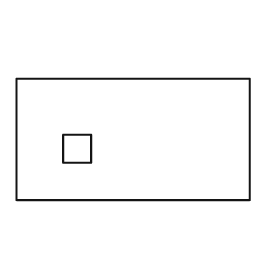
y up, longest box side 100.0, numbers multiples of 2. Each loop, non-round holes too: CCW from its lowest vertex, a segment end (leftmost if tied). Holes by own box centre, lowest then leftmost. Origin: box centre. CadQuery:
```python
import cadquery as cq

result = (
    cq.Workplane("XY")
    .moveTo(-50.0, -26.0)
    .lineTo(50.0, -26.0)
    .lineTo(50.0, 26.0)
    .lineTo(-50.0, 26.0)
    .close()
    .moveTo(-30.0, -10.0)
    .lineTo(-18.0, -10.0)
    .lineTo(-18.0, 2.0)
    .lineTo(-30.0, 2.0)
    .close()
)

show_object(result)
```